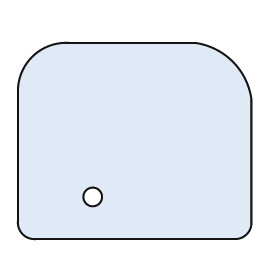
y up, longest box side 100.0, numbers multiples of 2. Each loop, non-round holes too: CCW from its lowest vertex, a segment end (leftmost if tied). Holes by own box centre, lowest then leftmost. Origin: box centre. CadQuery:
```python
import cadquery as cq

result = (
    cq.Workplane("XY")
    .moveTo(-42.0, -42.0)
    .lineTo(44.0, -42.0)
    .threePointArc((48.0, -40.0), (50.0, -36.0))
    .lineTo(50.0, 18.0)
    .threePointArc((42.0, 34.0), (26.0, 42.0))
    .lineTo(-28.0, 42.0)
    .threePointArc((-44.0, 36.0), (-50.0, 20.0))
    .lineTo(-50.0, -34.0)
    .threePointArc((-48.0, -40.0), (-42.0, -42.0))
    .close()
    .moveTo(-18.0, -24.0)
    .circle(4.0)
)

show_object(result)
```